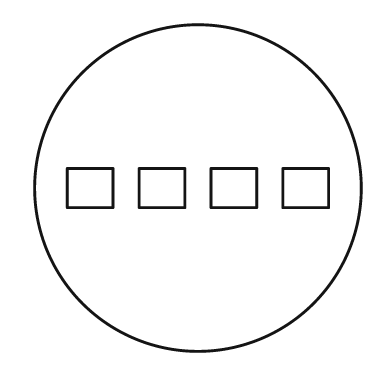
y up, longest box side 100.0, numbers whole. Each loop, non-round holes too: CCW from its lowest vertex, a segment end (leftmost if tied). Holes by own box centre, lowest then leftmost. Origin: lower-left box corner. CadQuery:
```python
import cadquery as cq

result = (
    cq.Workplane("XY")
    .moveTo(50.0, 50.0)
    .circle(50.0)
    .moveTo(10.0, 44.0)
    .lineTo(24.0, 44.0)
    .lineTo(24.0, 56.0)
    .lineTo(10.0, 56.0)
    .close()
    .moveTo(32.0, 44.0)
    .lineTo(46.0, 44.0)
    .lineTo(46.0, 56.0)
    .lineTo(32.0, 56.0)
    .close()
    .moveTo(54.0, 44.0)
    .lineTo(68.0, 44.0)
    .lineTo(68.0, 56.0)
    .lineTo(54.0, 56.0)
    .close()
    .moveTo(76.0, 44.0)
    .lineTo(90.0, 44.0)
    .lineTo(90.0, 56.0)
    .lineTo(76.0, 56.0)
    .close()
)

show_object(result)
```